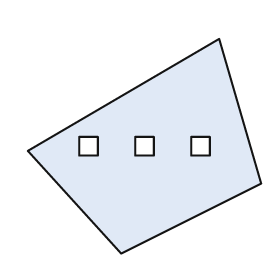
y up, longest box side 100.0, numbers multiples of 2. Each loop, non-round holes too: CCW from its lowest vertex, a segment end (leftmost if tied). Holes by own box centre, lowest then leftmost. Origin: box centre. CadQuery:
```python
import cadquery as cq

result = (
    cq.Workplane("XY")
    .moveTo(-10.0, -46.0)
    .lineTo(50.0, -16.0)
    .lineTo(32.0, 46.0)
    .lineTo(-50.0, -2.0)
    .close()
    .moveTo(-28.0, -4.0)
    .lineTo(-20.0, -4.0)
    .lineTo(-20.0, 4.0)
    .lineTo(-28.0, 4.0)
    .close()
    .moveTo(-4.0, -4.0)
    .lineTo(4.0, -4.0)
    .lineTo(4.0, 4.0)
    .lineTo(-4.0, 4.0)
    .close()
    .moveTo(20.0, -4.0)
    .lineTo(28.0, -4.0)
    .lineTo(28.0, 4.0)
    .lineTo(20.0, 4.0)
    .close()
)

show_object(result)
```